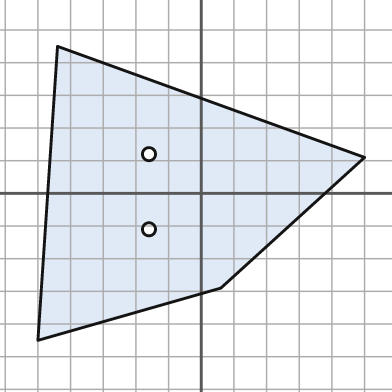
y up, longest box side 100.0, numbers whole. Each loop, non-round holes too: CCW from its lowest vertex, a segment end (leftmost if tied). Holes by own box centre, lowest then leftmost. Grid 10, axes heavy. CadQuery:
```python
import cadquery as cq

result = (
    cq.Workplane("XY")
    .moveTo(-50.0, -45.0)
    .lineTo(6.0, -29.0)
    .lineTo(50.0, 11.0)
    .lineTo(-44.0, 45.0)
    .close()
    .moveTo(-16.0, -11.0)
    .circle(2.0)
    .moveTo(-16.0, 12.0)
    .circle(2.0)
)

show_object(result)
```